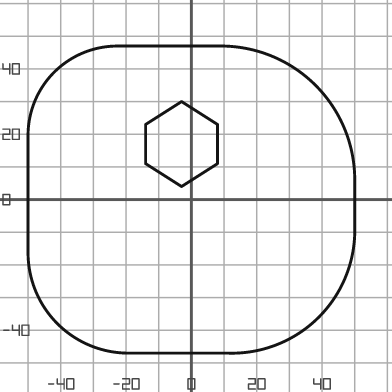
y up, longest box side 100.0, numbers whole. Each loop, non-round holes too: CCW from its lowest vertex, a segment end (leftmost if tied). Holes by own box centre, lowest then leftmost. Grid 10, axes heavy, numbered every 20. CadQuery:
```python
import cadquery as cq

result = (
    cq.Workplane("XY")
    .moveTo(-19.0, -47.0)
    .lineTo(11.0, -47.0)
    .threePointArc((39.0, -36.0), (50.0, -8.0))
    .lineTo(50.0, 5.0)
    .threePointArc((38.0, 35.0), (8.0, 47.0))
    .lineTo(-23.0, 47.0)
    .threePointArc((-42.0, 39.0), (-50.0, 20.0))
    .lineTo(-50.0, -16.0)
    .threePointArc((-41.0, -38.0), (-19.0, -47.0))
    .close()
    .moveTo(-3.0, 4.0)
    .lineTo(8.0, 11.0)
    .lineTo(8.0, 23.0)
    .lineTo(-3.0, 30.0)
    .lineTo(-14.0, 23.0)
    .lineTo(-14.0, 11.0)
    .close()
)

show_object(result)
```